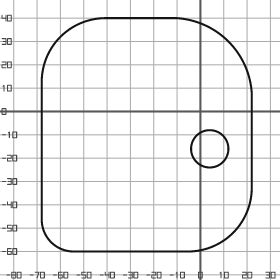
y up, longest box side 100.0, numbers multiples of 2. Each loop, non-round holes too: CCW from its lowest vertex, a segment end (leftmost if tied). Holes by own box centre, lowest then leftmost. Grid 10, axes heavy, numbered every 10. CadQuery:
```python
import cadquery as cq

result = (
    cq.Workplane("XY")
    .moveTo(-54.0, -60.0)
    .lineTo(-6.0, -60.0)
    .threePointArc((14.0, -52.0), (22.0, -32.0))
    .lineTo(22.0, 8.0)
    .threePointArc((12.0, 30.0), (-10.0, 40.0))
    .lineTo(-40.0, 40.0)
    .threePointArc((-60.0, 32.0), (-68.0, 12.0))
    .lineTo(-68.0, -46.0)
    .threePointArc((-64.0, -56.0), (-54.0, -60.0))
    .close()
    .moveTo(4.0, -16.0)
    .circle(8.0)
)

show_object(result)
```